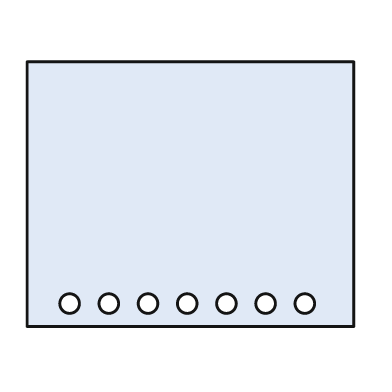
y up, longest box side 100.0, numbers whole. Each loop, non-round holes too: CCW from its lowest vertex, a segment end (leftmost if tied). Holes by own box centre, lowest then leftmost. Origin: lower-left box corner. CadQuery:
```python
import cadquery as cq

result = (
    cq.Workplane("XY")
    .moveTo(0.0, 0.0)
    .lineTo(100.0, 0.0)
    .lineTo(100.0, 81.0)
    .lineTo(0.0, 81.0)
    .close()
    .moveTo(13.0, 7.0)
    .circle(3.0)
    .moveTo(25.0, 7.0)
    .circle(3.0)
    .moveTo(37.0, 7.0)
    .circle(3.0)
    .moveTo(49.0, 7.0)
    .circle(3.0)
    .moveTo(61.0, 7.0)
    .circle(3.0)
    .moveTo(73.0, 7.0)
    .circle(3.0)
    .moveTo(85.0, 7.0)
    .circle(3.0)
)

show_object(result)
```